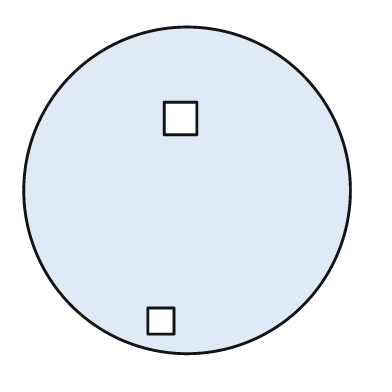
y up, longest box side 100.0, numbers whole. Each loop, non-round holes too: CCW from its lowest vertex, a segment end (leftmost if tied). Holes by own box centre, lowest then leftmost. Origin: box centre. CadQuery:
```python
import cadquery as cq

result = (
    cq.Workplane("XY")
    .moveTo(0.0, 0.0)
    .circle(50.0)
    .moveTo(-12.0, -44.0)
    .lineTo(-4.0, -44.0)
    .lineTo(-4.0, -36.0)
    .lineTo(-12.0, -36.0)
    .close()
    .moveTo(-7.0, 17.0)
    .lineTo(3.0, 17.0)
    .lineTo(3.0, 27.0)
    .lineTo(-7.0, 27.0)
    .close()
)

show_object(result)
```